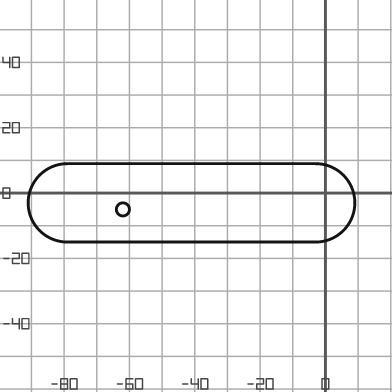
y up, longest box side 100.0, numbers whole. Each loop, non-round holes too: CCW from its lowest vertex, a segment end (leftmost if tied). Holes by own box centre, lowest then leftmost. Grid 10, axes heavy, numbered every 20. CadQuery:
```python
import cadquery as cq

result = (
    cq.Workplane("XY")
    .moveTo(-79.0, -15.0)
    .lineTo(-3.0, -15.0)
    .threePointArc((9.0, -3.0), (-3.0, 9.0))
    .lineTo(-79.0, 9.0)
    .threePointArc((-91.0, -3.0), (-79.0, -15.0))
    .close()
    .moveTo(-62.0, -5.0)
    .circle(2.0)
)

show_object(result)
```